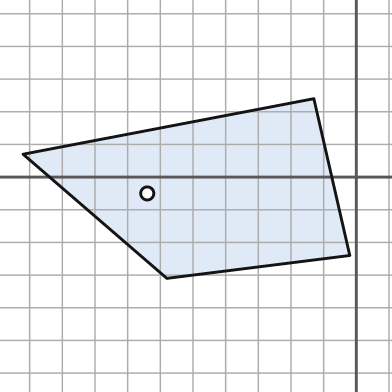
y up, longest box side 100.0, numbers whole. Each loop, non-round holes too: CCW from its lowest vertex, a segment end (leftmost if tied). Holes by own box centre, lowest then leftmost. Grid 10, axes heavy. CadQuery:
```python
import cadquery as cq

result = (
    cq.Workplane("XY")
    .moveTo(-58.0, -31.0)
    .lineTo(-2.0, -24.0)
    .lineTo(-13.0, 24.0)
    .lineTo(-102.0, 7.0)
    .close()
    .moveTo(-64.0, -5.0)
    .circle(2.0)
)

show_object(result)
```